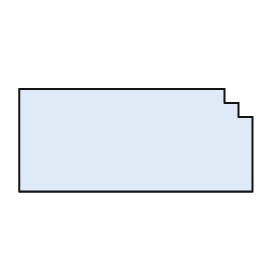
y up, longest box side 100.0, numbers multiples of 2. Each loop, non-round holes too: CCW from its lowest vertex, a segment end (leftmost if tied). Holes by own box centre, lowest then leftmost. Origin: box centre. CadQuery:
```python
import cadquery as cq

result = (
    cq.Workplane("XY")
    .moveTo(-50.0, -22.0)
    .lineTo(50.0, -22.0)
    .lineTo(50.0, 10.0)
    .lineTo(44.0, 10.0)
    .lineTo(44.0, 16.0)
    .lineTo(38.0, 16.0)
    .lineTo(38.0, 22.0)
    .lineTo(-50.0, 22.0)
    .close()
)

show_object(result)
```